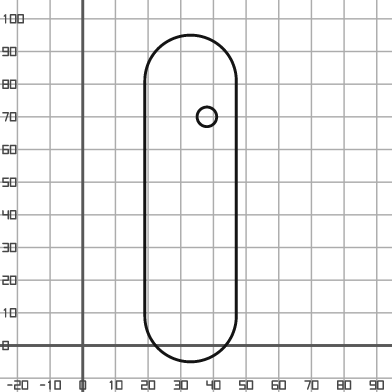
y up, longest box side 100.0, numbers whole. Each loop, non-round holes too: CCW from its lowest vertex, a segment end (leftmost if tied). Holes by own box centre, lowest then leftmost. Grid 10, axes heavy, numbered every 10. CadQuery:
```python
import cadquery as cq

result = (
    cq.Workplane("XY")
    .moveTo(19.0, 9.0)
    .threePointArc((33.0, -5.0), (47.0, 9.0))
    .lineTo(47.0, 81.0)
    .threePointArc((33.0, 95.0), (19.0, 81.0))
    .close()
    .moveTo(38.0, 70.0)
    .circle(3.0)
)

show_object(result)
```